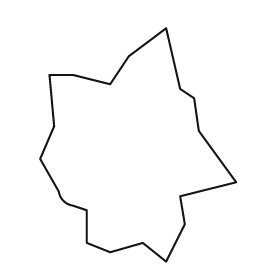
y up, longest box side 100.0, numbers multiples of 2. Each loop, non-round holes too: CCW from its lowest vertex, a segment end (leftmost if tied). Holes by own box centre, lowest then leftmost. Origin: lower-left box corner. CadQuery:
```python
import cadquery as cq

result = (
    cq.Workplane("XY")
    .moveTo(54.0, 0.0)
    .lineTo(62.0, 16.0)
    .lineTo(60.0, 28.0)
    .lineTo(84.0, 34.0)
    .lineTo(68.0, 56.0)
    .lineTo(66.0, 70.0)
    .lineTo(60.0, 74.0)
    .lineTo(54.0, 100.0)
    .lineTo(38.0, 88.0)
    .lineTo(30.0, 76.0)
    .lineTo(14.0, 80.0)
    .lineTo(4.0, 80.0)
    .lineTo(6.0, 58.0)
    .lineTo(0.0, 44.0)
    .lineTo(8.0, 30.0)
    .threePointArc((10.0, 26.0), (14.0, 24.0))
    .lineTo(20.0, 22.0)
    .lineTo(20.0, 8.0)
    .lineTo(30.0, 4.0)
    .lineTo(44.0, 8.0)
    .close()
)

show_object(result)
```